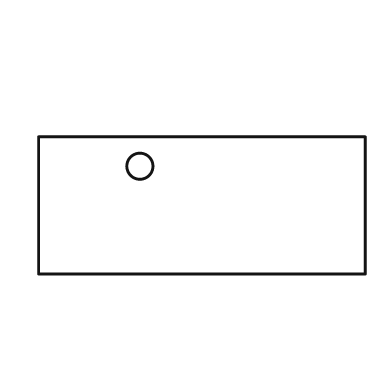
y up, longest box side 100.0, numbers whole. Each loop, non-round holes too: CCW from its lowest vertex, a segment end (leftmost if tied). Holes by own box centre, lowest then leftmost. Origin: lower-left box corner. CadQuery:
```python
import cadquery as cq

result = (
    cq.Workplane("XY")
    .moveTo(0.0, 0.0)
    .lineTo(100.0, 0.0)
    .lineTo(100.0, 42.0)
    .lineTo(0.0, 42.0)
    .close()
    .moveTo(31.0, 33.0)
    .circle(4.0)
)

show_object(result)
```